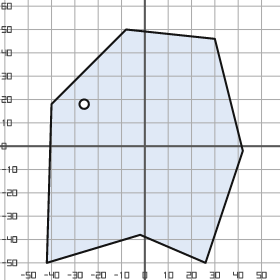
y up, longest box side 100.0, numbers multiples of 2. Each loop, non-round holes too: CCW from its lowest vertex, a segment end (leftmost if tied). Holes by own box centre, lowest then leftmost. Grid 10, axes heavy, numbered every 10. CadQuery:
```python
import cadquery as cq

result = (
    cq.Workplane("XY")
    .moveTo(-42.0, -50.0)
    .lineTo(-2.0, -38.0)
    .lineTo(26.0, -50.0)
    .lineTo(42.0, -2.0)
    .lineTo(30.0, 46.0)
    .lineTo(-8.0, 50.0)
    .lineTo(-40.0, 18.0)
    .close()
    .moveTo(-26.0, 18.0)
    .circle(2.0)
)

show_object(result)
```